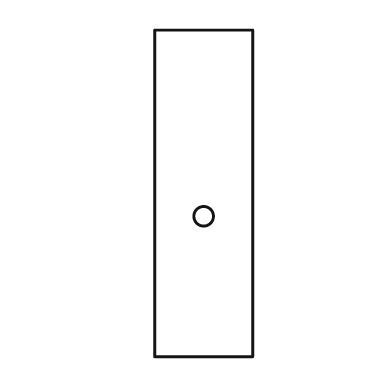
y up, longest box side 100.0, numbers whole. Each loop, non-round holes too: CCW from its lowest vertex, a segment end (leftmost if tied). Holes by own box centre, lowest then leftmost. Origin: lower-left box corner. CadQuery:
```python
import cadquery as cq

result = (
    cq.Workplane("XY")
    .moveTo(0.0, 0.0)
    .lineTo(30.0, 0.0)
    .lineTo(30.0, 100.0)
    .lineTo(0.0, 100.0)
    .close()
    .moveTo(15.0, 43.0)
    .circle(3.0)
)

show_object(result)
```